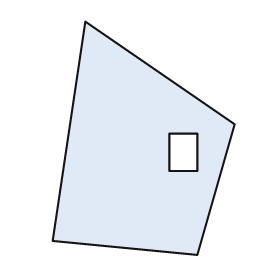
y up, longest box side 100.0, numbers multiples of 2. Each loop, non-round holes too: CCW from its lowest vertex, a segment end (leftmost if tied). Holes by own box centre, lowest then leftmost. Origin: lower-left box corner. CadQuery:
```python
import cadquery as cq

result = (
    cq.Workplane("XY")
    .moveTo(62.0, 0.0)
    .lineTo(78.0, 56.0)
    .lineTo(14.0, 100.0)
    .lineTo(0.0, 6.0)
    .close()
    .moveTo(50.0, 36.0)
    .lineTo(62.0, 36.0)
    .lineTo(62.0, 52.0)
    .lineTo(50.0, 52.0)
    .close()
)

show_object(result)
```